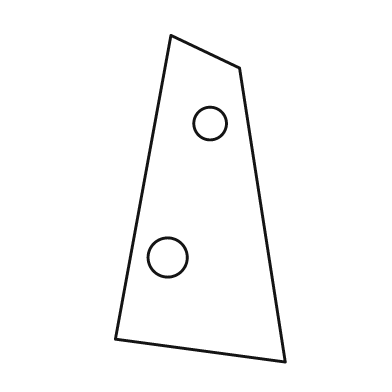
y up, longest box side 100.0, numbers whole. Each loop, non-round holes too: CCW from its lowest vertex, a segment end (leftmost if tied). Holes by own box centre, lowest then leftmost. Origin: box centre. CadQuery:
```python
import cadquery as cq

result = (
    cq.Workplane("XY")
    .moveTo(26.0, -50.0)
    .lineTo(12.0, 40.0)
    .lineTo(-9.0, 50.0)
    .lineTo(-26.0, -43.0)
    .close()
    .moveTo(-10.0, -18.0)
    .circle(6.0)
    .moveTo(3.0, 23.0)
    .circle(5.0)
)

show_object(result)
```